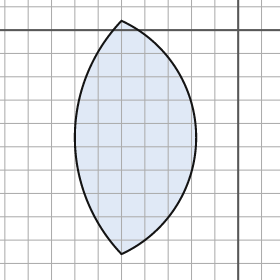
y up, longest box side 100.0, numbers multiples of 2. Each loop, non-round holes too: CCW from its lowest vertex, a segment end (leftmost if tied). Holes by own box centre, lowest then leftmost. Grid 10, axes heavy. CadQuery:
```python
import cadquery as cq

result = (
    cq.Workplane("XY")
    .moveTo(-50.0, -96.0)
    .threePointArc((-18.0, -46.0), (-50.0, 4.0))
    .threePointArc((-70.0, -46.0), (-50.0, -96.0))
    .close()
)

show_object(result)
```